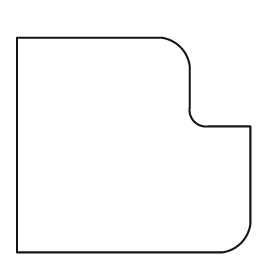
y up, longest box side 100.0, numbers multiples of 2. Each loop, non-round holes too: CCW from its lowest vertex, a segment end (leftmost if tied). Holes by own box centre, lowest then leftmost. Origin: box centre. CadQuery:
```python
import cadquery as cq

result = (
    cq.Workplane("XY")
    .moveTo(-50.0, -46.0)
    .lineTo(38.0, -46.0)
    .threePointArc((46.0, -42.0), (50.0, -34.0))
    .lineTo(50.0, 8.0)
    .lineTo(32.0, 8.0)
    .threePointArc((26.0, 10.0), (24.0, 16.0))
    .lineTo(24.0, 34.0)
    .threePointArc((20.0, 42.0), (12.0, 46.0))
    .lineTo(-50.0, 46.0)
    .close()
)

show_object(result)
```